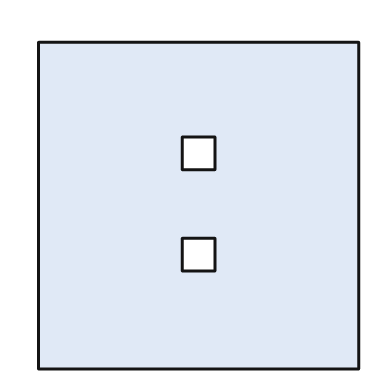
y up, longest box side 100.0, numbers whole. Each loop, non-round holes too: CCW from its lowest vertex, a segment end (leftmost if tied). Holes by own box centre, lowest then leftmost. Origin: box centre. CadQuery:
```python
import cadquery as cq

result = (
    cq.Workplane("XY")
    .moveTo(-49.0, -50.0)
    .lineTo(49.0, -50.0)
    .lineTo(49.0, 50.0)
    .lineTo(-49.0, 50.0)
    .close()
    .moveTo(-5.0, -20.0)
    .lineTo(5.0, -20.0)
    .lineTo(5.0, -10.0)
    .lineTo(-5.0, -10.0)
    .close()
    .moveTo(-5.0, 11.0)
    .lineTo(5.0, 11.0)
    .lineTo(5.0, 21.0)
    .lineTo(-5.0, 21.0)
    .close()
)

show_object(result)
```